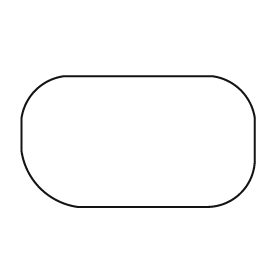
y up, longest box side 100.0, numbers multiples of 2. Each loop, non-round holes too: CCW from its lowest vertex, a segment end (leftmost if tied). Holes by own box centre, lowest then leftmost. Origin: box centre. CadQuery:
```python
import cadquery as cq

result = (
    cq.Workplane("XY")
    .moveTo(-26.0, -28.0)
    .lineTo(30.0, -28.0)
    .threePointArc((44.0, -22.0), (50.0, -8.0))
    .lineTo(50.0, 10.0)
    .threePointArc((44.0, 22.0), (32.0, 28.0))
    .lineTo(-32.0, 28.0)
    .threePointArc((-44.0, 22.0), (-50.0, 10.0))
    .lineTo(-50.0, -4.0)
    .threePointArc((-42.0, -20.0), (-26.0, -28.0))
    .close()
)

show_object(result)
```